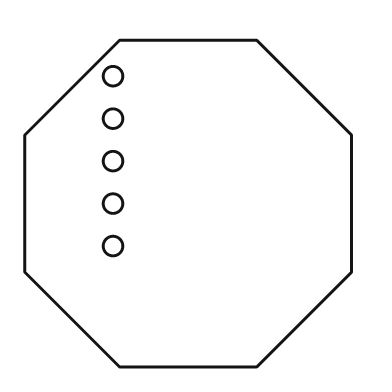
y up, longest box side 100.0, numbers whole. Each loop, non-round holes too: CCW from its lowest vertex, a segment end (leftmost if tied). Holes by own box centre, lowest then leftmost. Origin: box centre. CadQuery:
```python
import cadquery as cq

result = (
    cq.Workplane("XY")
    .moveTo(-21.0, -50.0)
    .lineTo(21.0, -50.0)
    .lineTo(50.0, -21.0)
    .lineTo(50.0, 21.0)
    .lineTo(21.0, 50.0)
    .lineTo(-21.0, 50.0)
    .lineTo(-50.0, 21.0)
    .lineTo(-50.0, -21.0)
    .close()
    .moveTo(-23.0, -13.0)
    .circle(3.0)
    .moveTo(-23.0, 0.0)
    .circle(3.0)
    .moveTo(-23.0, 13.0)
    .circle(3.0)
    .moveTo(-23.0, 26.0)
    .circle(3.0)
    .moveTo(-23.0, 39.0)
    .circle(3.0)
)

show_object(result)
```